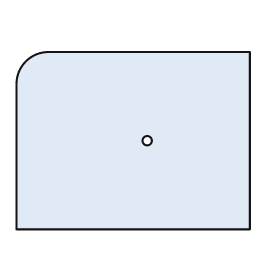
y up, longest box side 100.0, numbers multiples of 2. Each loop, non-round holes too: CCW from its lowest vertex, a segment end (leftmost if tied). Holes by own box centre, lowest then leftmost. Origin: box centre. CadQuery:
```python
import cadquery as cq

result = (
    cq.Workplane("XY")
    .moveTo(-50.0, -38.0)
    .lineTo(50.0, -38.0)
    .lineTo(50.0, 38.0)
    .lineTo(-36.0, 38.0)
    .threePointArc((-46.0, 34.0), (-50.0, 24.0))
    .close()
    .moveTo(6.0, 0.0)
    .circle(2.0)
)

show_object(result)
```